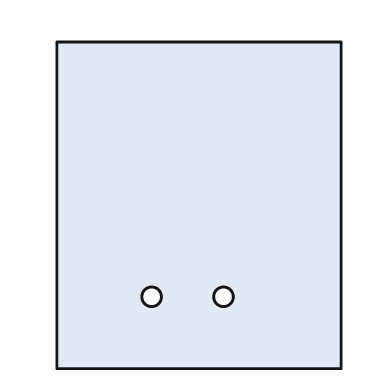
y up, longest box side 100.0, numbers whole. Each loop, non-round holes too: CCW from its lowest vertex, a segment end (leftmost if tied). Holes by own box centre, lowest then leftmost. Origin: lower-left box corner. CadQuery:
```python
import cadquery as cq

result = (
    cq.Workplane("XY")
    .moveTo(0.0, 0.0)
    .lineTo(87.0, 0.0)
    .lineTo(87.0, 100.0)
    .lineTo(0.0, 100.0)
    .close()
    .moveTo(29.0, 22.0)
    .circle(3.0)
    .moveTo(51.0, 22.0)
    .circle(3.0)
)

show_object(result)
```